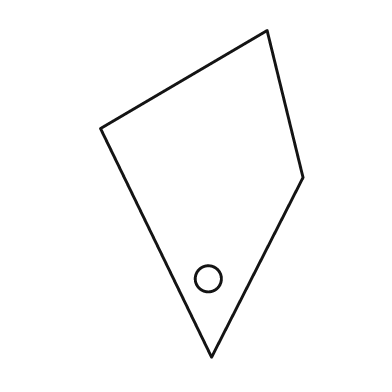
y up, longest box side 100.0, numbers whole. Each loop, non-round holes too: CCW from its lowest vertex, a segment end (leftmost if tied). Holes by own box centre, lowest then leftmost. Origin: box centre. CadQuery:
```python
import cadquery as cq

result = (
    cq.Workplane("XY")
    .moveTo(3.0, -50.0)
    .lineTo(31.0, 5.0)
    .lineTo(20.0, 50.0)
    .lineTo(-31.0, 20.0)
    .close()
    .moveTo(2.0, -26.0)
    .circle(4.0)
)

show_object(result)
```